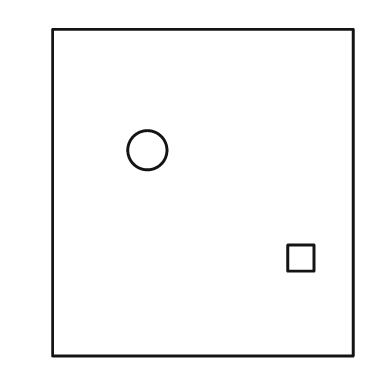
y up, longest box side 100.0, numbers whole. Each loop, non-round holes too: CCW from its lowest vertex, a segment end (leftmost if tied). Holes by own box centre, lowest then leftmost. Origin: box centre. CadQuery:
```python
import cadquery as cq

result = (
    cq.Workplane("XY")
    .moveTo(-46.0, -50.0)
    .lineTo(46.0, -50.0)
    .lineTo(46.0, 50.0)
    .lineTo(-46.0, 50.0)
    .close()
    .moveTo(26.0, -24.0)
    .lineTo(34.0, -24.0)
    .lineTo(34.0, -16.0)
    .lineTo(26.0, -16.0)
    .close()
    .moveTo(-17.0, 13.0)
    .circle(6.0)
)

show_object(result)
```